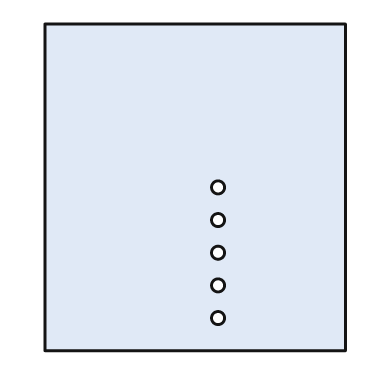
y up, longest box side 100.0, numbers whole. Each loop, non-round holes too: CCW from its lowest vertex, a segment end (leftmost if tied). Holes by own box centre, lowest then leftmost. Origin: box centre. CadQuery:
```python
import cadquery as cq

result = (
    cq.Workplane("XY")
    .moveTo(-46.0, -50.0)
    .lineTo(46.0, -50.0)
    .lineTo(46.0, 50.0)
    .lineTo(-46.0, 50.0)
    .close()
    .moveTo(7.0, -40.0)
    .circle(2.0)
    .moveTo(7.0, -30.0)
    .circle(2.0)
    .moveTo(7.0, -20.0)
    .circle(2.0)
    .moveTo(7.0, -10.0)
    .circle(2.0)
    .moveTo(7.0, 0.0)
    .circle(2.0)
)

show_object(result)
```